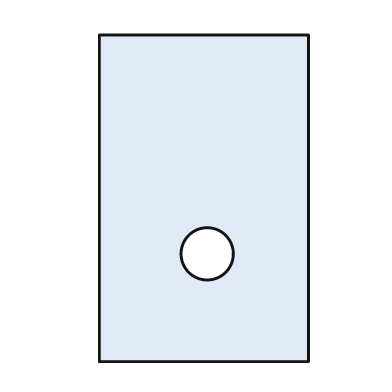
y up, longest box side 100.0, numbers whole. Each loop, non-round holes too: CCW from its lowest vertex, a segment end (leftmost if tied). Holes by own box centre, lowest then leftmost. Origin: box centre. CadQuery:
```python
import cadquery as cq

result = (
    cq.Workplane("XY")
    .moveTo(-32.0, -50.0)
    .lineTo(32.0, -50.0)
    .lineTo(32.0, 50.0)
    .lineTo(-32.0, 50.0)
    .close()
    .moveTo(1.0, -17.0)
    .circle(8.0)
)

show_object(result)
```